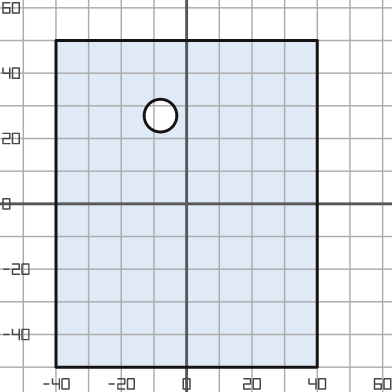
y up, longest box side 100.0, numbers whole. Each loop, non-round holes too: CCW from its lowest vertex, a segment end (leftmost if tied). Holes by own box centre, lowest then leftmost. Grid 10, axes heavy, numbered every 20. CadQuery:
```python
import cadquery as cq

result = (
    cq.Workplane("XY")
    .moveTo(-40.0, -50.0)
    .lineTo(40.0, -50.0)
    .lineTo(40.0, 50.0)
    .lineTo(-40.0, 50.0)
    .close()
    .moveTo(-8.0, 27.0)
    .circle(5.0)
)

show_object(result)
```